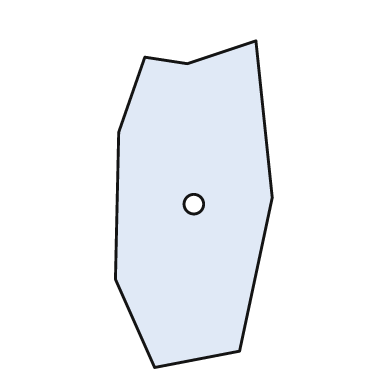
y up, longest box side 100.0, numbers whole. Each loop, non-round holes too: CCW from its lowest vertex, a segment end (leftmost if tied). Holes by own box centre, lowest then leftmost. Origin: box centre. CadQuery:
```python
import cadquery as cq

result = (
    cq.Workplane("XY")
    .moveTo(-12.0, -50.0)
    .lineTo(14.0, -45.0)
    .lineTo(24.0, 2.0)
    .lineTo(19.0, 50.0)
    .lineTo(-2.0, 43.0)
    .lineTo(-15.0, 45.0)
    .lineTo(-23.0, 22.0)
    .lineTo(-24.0, -23.0)
    .close()
    .moveTo(0.0, 0.0)
    .circle(3.0)
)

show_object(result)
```